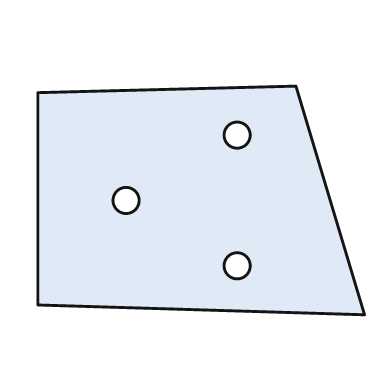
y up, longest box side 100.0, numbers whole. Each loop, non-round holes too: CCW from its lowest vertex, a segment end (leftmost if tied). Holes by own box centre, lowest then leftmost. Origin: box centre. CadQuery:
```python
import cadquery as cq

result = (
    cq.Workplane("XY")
    .moveTo(50.0, -35.0)
    .lineTo(29.0, 35.0)
    .lineTo(-50.0, 33.0)
    .lineTo(-50.0, -32.0)
    .close()
    .moveTo(11.0, -20.0)
    .circle(4.0)
    .moveTo(-23.0, 0.0)
    .circle(4.0)
    .moveTo(11.0, 20.0)
    .circle(4.0)
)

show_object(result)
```